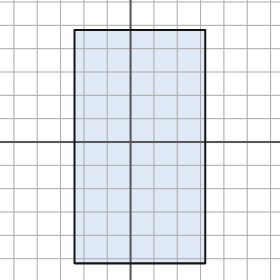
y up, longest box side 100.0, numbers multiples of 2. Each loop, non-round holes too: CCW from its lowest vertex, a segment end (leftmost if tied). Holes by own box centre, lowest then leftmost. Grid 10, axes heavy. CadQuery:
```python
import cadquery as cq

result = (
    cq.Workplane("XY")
    .moveTo(-24.0, -52.0)
    .lineTo(32.0, -52.0)
    .lineTo(32.0, 48.0)
    .lineTo(-24.0, 48.0)
    .close()
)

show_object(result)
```